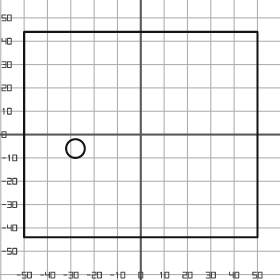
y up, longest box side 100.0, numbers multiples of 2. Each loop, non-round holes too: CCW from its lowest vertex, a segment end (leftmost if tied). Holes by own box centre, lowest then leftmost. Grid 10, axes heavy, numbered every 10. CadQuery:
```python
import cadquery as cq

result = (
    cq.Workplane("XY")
    .moveTo(-50.0, -44.0)
    .lineTo(50.0, -44.0)
    .lineTo(50.0, 44.0)
    .lineTo(-50.0, 44.0)
    .close()
    .moveTo(-28.0, -6.0)
    .circle(4.0)
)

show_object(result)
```